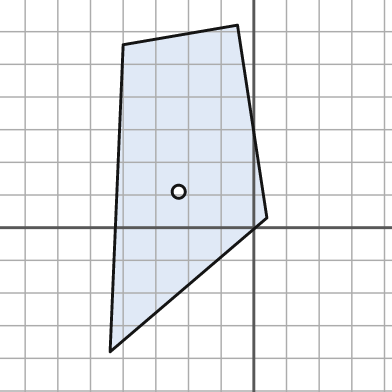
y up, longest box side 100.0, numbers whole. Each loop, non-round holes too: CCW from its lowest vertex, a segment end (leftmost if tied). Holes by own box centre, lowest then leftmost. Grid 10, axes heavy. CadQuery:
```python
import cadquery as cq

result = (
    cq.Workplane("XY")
    .moveTo(-44.0, -38.0)
    .lineTo(4.0, 3.0)
    .lineTo(-5.0, 62.0)
    .lineTo(-40.0, 56.0)
    .close()
    .moveTo(-23.0, 11.0)
    .circle(2.0)
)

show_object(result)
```